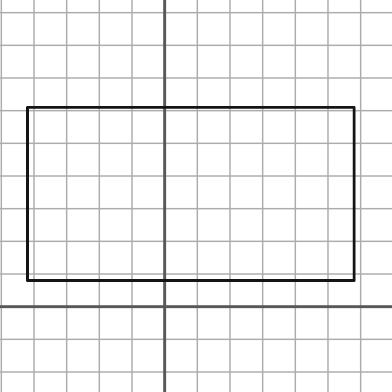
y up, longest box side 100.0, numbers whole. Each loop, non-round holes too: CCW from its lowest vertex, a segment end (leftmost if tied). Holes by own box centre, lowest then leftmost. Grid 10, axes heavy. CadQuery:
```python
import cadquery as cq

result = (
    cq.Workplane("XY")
    .moveTo(-42.0, 8.0)
    .lineTo(58.0, 8.0)
    .lineTo(58.0, 61.0)
    .lineTo(-42.0, 61.0)
    .close()
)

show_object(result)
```